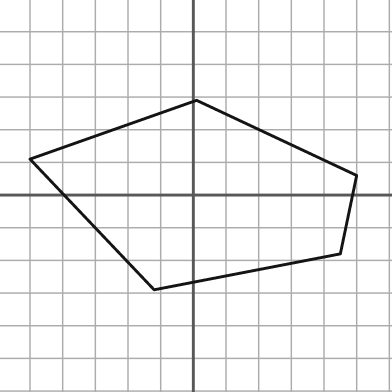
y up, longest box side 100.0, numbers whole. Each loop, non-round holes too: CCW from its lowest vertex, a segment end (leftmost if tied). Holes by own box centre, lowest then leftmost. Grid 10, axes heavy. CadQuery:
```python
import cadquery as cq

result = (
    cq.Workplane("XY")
    .moveTo(-12.0, -29.0)
    .lineTo(45.0, -18.0)
    .lineTo(50.0, 6.0)
    .lineTo(1.0, 29.0)
    .lineTo(-50.0, 11.0)
    .close()
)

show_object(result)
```